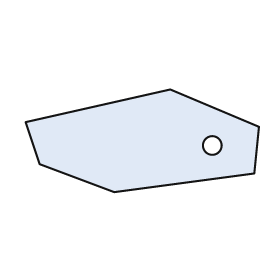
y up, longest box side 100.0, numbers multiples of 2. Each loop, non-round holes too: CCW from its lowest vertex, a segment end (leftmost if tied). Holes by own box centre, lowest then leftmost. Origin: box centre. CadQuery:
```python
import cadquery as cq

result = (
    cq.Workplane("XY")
    .moveTo(-12.0, -22.0)
    .lineTo(48.0, -14.0)
    .lineTo(50.0, 6.0)
    .lineTo(12.0, 22.0)
    .lineTo(-50.0, 8.0)
    .lineTo(-44.0, -10.0)
    .close()
    .moveTo(30.0, -2.0)
    .circle(4.0)
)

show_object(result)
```